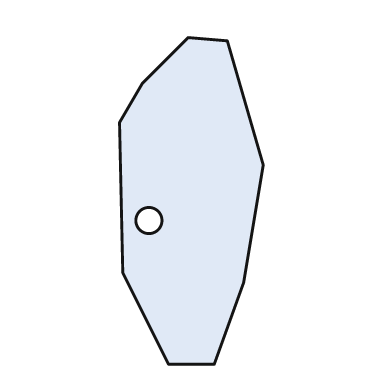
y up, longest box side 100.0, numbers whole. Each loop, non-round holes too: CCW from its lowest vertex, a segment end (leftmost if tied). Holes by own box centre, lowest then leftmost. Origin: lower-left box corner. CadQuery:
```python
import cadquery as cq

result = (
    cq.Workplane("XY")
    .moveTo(15.0, 0.0)
    .lineTo(29.0, 0.0)
    .lineTo(38.0, 25.0)
    .lineTo(44.0, 61.0)
    .lineTo(33.0, 99.0)
    .lineTo(21.0, 100.0)
    .lineTo(7.0, 86.0)
    .lineTo(0.0, 74.0)
    .lineTo(1.0, 28.0)
    .close()
    .moveTo(9.0, 44.0)
    .circle(4.0)
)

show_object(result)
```